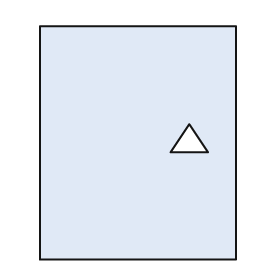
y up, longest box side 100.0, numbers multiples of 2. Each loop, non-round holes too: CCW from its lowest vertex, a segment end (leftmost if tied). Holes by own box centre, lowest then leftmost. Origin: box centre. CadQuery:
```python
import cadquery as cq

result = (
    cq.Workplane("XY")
    .moveTo(-42.0, -50.0)
    .lineTo(42.0, -50.0)
    .lineTo(42.0, 50.0)
    .lineTo(-42.0, 50.0)
    .close()
    .moveTo(14.0, -4.0)
    .lineTo(30.0, -4.0)
    .lineTo(22.0, 8.0)
    .close()
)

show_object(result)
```